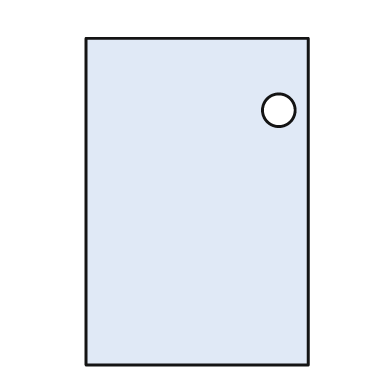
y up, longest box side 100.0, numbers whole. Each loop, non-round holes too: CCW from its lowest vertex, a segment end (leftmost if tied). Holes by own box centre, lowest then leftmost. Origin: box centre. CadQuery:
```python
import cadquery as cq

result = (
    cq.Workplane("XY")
    .moveTo(-34.0, -50.0)
    .lineTo(34.0, -50.0)
    .lineTo(34.0, 50.0)
    .lineTo(-34.0, 50.0)
    .close()
    .moveTo(25.0, 28.0)
    .circle(5.0)
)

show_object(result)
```